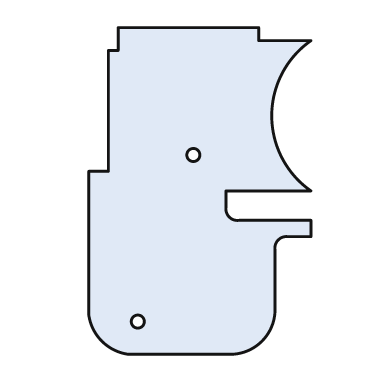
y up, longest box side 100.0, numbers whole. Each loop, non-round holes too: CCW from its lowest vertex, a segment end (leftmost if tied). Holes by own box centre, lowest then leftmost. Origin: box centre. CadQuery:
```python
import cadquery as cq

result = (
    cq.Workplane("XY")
    .moveTo(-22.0, -50.0)
    .lineTo(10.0, -50.0)
    .threePointArc((19.0, -46.0), (23.0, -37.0))
    .lineTo(23.0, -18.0)
    .threePointArc((24.0, -15.0), (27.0, -14.0))
    .lineTo(34.0, -14.0)
    .lineTo(34.0, -9.0)
    .lineTo(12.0, -9.0)
    .threePointArc((9.0, -8.0), (8.0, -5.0))
    .lineTo(8.0, 0.0)
    .lineTo(34.0, 0.0)
    .threePointArc((22.0, 23.0), (34.0, 46.0))
    .lineTo(18.0, 46.0)
    .lineTo(18.0, 50.0)
    .lineTo(-25.0, 50.0)
    .lineTo(-25.0, 43.0)
    .lineTo(-28.0, 43.0)
    .lineTo(-28.0, 6.0)
    .lineTo(-34.0, 6.0)
    .lineTo(-34.0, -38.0)
    .threePointArc((-30.0, -46.0), (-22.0, -50.0))
    .close()
    .moveTo(-19.0, -40.0)
    .circle(2.0)
    .moveTo(-2.0, 11.0)
    .circle(2.0)
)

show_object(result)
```